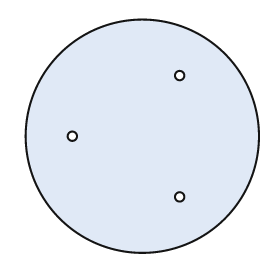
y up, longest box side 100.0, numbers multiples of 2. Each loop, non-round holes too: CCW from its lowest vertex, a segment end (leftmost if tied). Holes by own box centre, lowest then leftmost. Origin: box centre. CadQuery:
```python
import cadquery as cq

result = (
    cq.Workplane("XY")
    .moveTo(0.0, 0.0)
    .circle(50.0)
    .moveTo(16.0, -26.0)
    .circle(2.0)
    .moveTo(-30.0, 0.0)
    .circle(2.0)
    .moveTo(16.0, 26.0)
    .circle(2.0)
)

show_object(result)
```